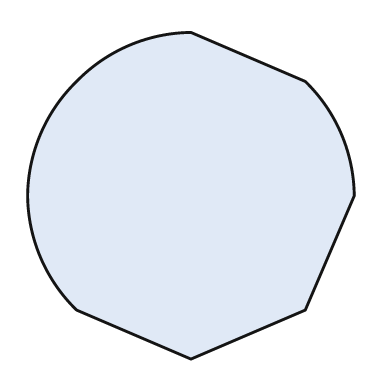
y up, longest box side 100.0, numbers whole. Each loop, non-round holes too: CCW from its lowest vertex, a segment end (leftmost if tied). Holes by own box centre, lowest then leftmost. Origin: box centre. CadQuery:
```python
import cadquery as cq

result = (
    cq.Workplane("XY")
    .moveTo(0.0, -50.0)
    .lineTo(35.0, -35.0)
    .lineTo(50.0, 0.0)
    .threePointArc((46.0, 19.0), (35.0, 35.0))
    .lineTo(0.0, 50.0)
    .threePointArc((-19.0, 46.0), (-35.0, 35.0))
    .threePointArc((-46.0, 19.0), (-50.0, 0.0))
    .threePointArc((-46.0, -19.0), (-35.0, -35.0))
    .close()
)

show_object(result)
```